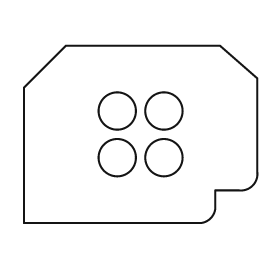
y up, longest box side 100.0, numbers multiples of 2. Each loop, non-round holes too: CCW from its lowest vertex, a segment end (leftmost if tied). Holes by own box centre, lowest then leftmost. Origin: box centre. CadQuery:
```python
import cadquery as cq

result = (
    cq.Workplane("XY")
    .moveTo(-50.0, -38.0)
    .lineTo(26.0, -38.0)
    .threePointArc((30.0, -36.0), (32.0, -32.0))
    .lineTo(32.0, -24.0)
    .lineTo(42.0, -24.0)
    .threePointArc((48.0, -22.0), (50.0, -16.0))
    .lineTo(50.0, 24.0)
    .lineTo(34.0, 38.0)
    .lineTo(-32.0, 38.0)
    .lineTo(-50.0, 20.0)
    .close()
    .moveTo(-10.0, -10.0)
    .circle(8.0)
    .moveTo(10.0, -10.0)
    .circle(8.0)
    .moveTo(-10.0, 10.0)
    .circle(8.0)
    .moveTo(10.0, 10.0)
    .circle(8.0)
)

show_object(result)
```